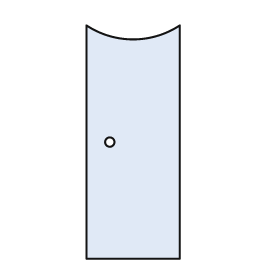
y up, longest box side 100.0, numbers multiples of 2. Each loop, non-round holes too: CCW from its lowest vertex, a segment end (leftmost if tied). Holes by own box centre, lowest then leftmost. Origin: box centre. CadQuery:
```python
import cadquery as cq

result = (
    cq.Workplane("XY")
    .moveTo(-20.0, -50.0)
    .lineTo(20.0, -50.0)
    .lineTo(20.0, 50.0)
    .threePointArc((0.0, 44.0), (-20.0, 50.0))
    .close()
    .moveTo(-10.0, 0.0)
    .circle(2.0)
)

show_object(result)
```